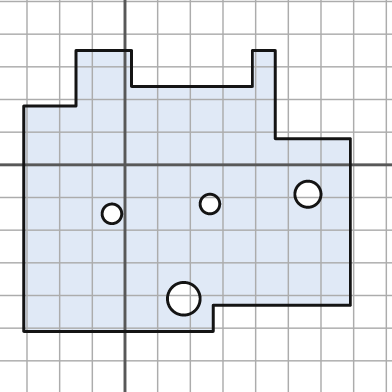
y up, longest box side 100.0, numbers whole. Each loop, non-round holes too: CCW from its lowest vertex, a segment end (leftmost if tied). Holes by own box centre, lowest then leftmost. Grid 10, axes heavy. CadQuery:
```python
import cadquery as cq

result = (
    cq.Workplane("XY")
    .moveTo(-31.0, -51.0)
    .lineTo(27.0, -51.0)
    .lineTo(27.0, -43.0)
    .lineTo(69.0, -43.0)
    .lineTo(69.0, 8.0)
    .lineTo(46.0, 8.0)
    .lineTo(46.0, 35.0)
    .lineTo(39.0, 35.0)
    .lineTo(39.0, 24.0)
    .lineTo(2.0, 24.0)
    .lineTo(2.0, 35.0)
    .lineTo(-15.0, 35.0)
    .lineTo(-15.0, 18.0)
    .lineTo(-31.0, 18.0)
    .close()
    .moveTo(18.0, -41.0)
    .circle(5.0)
    .moveTo(-4.0, -15.0)
    .circle(3.0)
    .moveTo(26.0, -12.0)
    .circle(3.0)
    .moveTo(56.0, -9.0)
    .circle(4.0)
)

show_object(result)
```